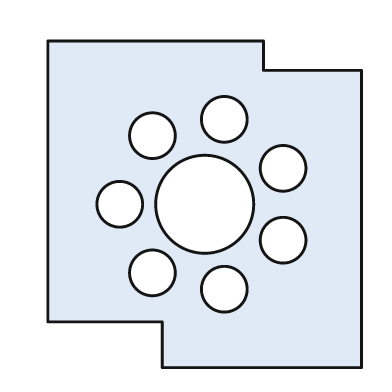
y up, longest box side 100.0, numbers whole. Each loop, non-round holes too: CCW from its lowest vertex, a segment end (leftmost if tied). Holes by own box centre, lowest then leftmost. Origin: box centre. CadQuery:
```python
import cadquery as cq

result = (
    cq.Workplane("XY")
    .moveTo(-13.0, -50.0)
    .lineTo(48.0, -50.0)
    .lineTo(48.0, 41.0)
    .lineTo(18.0, 41.0)
    .lineTo(18.0, 50.0)
    .lineTo(-48.0, 50.0)
    .lineTo(-48.0, -36.0)
    .lineTo(-13.0, -36.0)
    .close()
    .moveTo(6.0, -26.0)
    .circle(7.0)
    .moveTo(-16.0, -21.0)
    .circle(7.0)
    .moveTo(24.0, -11.0)
    .circle(7.0)
    .moveTo(-26.0, 0.0)
    .circle(7.0)
    .moveTo(0.0, 0.0)
    .circle(15.0)
    .moveTo(24.0, 11.0)
    .circle(7.0)
    .moveTo(-16.0, 21.0)
    .circle(7.0)
    .moveTo(6.0, 26.0)
    .circle(7.0)
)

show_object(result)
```